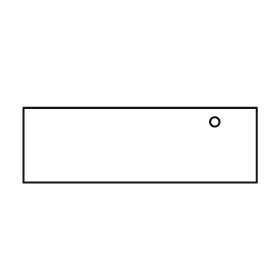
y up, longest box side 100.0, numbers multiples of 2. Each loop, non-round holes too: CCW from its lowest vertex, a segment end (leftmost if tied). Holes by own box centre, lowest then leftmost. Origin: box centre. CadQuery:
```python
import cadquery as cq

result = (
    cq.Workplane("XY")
    .moveTo(-50.0, -16.0)
    .lineTo(50.0, -16.0)
    .lineTo(50.0, 16.0)
    .lineTo(-50.0, 16.0)
    .close()
    .moveTo(32.0, 10.0)
    .circle(2.0)
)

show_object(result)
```